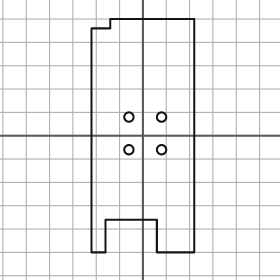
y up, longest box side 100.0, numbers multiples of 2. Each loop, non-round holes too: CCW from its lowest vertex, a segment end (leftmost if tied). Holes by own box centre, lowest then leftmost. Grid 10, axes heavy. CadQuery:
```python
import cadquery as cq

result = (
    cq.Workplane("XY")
    .moveTo(-22.0, -50.0)
    .lineTo(-16.0, -50.0)
    .lineTo(-16.0, -36.0)
    .lineTo(6.0, -36.0)
    .lineTo(6.0, -50.0)
    .lineTo(22.0, -50.0)
    .lineTo(22.0, 50.0)
    .lineTo(-14.0, 50.0)
    .lineTo(-14.0, 46.0)
    .lineTo(-22.0, 46.0)
    .close()
    .moveTo(-6.0, -6.0)
    .circle(2.0)
    .moveTo(8.0, -6.0)
    .circle(2.0)
    .moveTo(-6.0, 8.0)
    .circle(2.0)
    .moveTo(8.0, 8.0)
    .circle(2.0)
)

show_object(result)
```